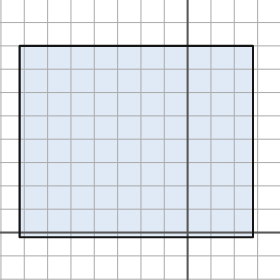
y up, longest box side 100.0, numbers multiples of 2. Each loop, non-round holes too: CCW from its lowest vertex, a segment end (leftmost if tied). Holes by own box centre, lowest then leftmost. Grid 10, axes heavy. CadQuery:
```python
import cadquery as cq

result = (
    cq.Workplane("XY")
    .moveTo(-72.0, -2.0)
    .lineTo(28.0, -2.0)
    .lineTo(28.0, 80.0)
    .lineTo(-72.0, 80.0)
    .close()
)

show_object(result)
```